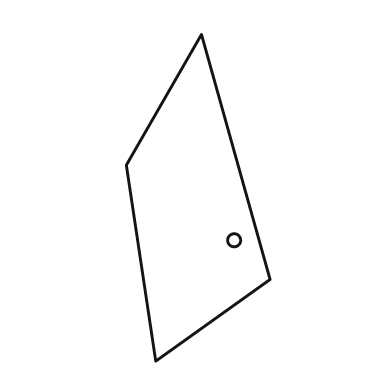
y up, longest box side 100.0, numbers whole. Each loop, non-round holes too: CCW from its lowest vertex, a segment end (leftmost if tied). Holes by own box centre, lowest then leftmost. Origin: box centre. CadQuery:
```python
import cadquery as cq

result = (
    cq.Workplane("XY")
    .moveTo(-13.0, -50.0)
    .lineTo(22.0, -25.0)
    .lineTo(1.0, 50.0)
    .lineTo(-22.0, 10.0)
    .close()
    .moveTo(11.0, -13.0)
    .circle(2.0)
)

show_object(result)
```